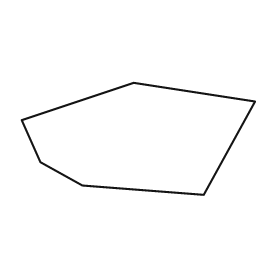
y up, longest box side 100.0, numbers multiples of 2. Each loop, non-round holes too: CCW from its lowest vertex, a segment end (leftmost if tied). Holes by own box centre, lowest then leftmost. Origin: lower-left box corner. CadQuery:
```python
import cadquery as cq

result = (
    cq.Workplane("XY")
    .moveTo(78.0, 0.0)
    .lineTo(100.0, 40.0)
    .lineTo(48.0, 48.0)
    .lineTo(0.0, 32.0)
    .lineTo(8.0, 14.0)
    .lineTo(26.0, 4.0)
    .close()
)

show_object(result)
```